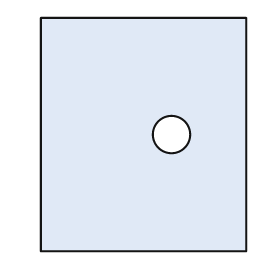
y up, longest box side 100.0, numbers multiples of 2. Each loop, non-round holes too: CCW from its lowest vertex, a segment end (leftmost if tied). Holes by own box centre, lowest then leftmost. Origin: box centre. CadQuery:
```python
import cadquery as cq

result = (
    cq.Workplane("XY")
    .moveTo(-44.0, -50.0)
    .lineTo(44.0, -50.0)
    .lineTo(44.0, 50.0)
    .lineTo(-44.0, 50.0)
    .close()
    .moveTo(12.0, 0.0)
    .circle(8.0)
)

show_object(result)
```